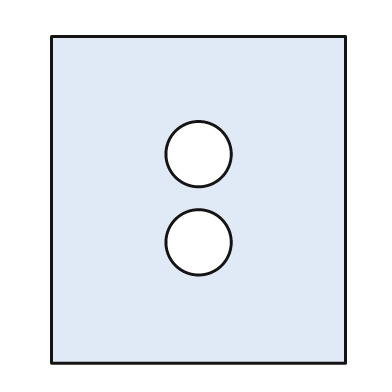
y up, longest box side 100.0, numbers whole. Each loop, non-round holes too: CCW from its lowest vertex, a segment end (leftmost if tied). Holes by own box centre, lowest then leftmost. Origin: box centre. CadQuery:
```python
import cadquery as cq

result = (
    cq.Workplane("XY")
    .moveTo(-45.0, -50.0)
    .lineTo(45.0, -50.0)
    .lineTo(45.0, 50.0)
    .lineTo(-45.0, 50.0)
    .close()
    .moveTo(0.0, -13.0)
    .circle(10.0)
    .moveTo(0.0, 14.0)
    .circle(10.0)
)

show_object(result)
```